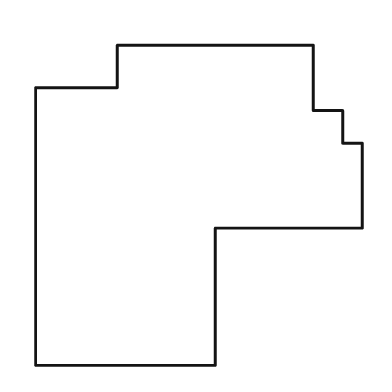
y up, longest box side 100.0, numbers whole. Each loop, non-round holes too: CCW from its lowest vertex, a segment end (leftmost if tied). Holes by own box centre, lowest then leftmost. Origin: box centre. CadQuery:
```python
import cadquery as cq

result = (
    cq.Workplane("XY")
    .moveTo(-50.0, -49.0)
    .lineTo(5.0, -49.0)
    .lineTo(5.0, -7.0)
    .lineTo(50.0, -7.0)
    .lineTo(50.0, 19.0)
    .lineTo(44.0, 19.0)
    .lineTo(44.0, 29.0)
    .lineTo(35.0, 29.0)
    .lineTo(35.0, 49.0)
    .lineTo(-25.0, 49.0)
    .lineTo(-25.0, 36.0)
    .lineTo(-50.0, 36.0)
    .close()
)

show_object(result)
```